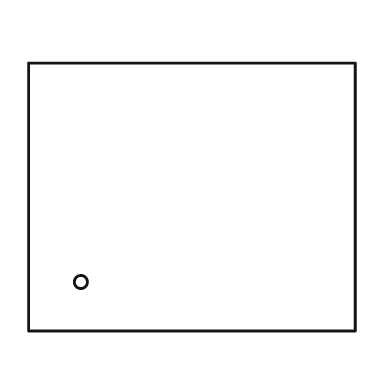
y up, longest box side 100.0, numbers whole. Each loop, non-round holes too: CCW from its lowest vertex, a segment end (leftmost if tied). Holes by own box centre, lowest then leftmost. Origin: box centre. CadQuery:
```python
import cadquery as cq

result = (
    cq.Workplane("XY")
    .moveTo(-50.0, -41.0)
    .lineTo(50.0, -41.0)
    .lineTo(50.0, 41.0)
    .lineTo(-50.0, 41.0)
    .close()
    .moveTo(-34.0, -26.0)
    .circle(2.0)
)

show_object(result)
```